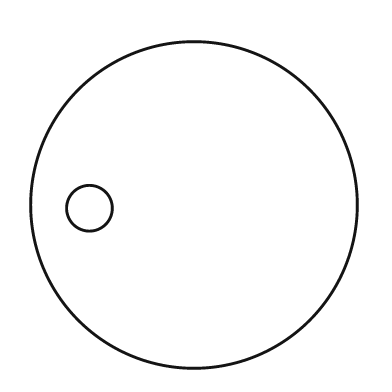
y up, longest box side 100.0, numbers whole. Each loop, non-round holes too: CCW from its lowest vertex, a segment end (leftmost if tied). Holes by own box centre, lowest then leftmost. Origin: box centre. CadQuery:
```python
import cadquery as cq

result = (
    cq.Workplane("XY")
    .moveTo(0.0, 0.0)
    .circle(50.0)
    .moveTo(-32.0, -1.0)
    .circle(7.0)
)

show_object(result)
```